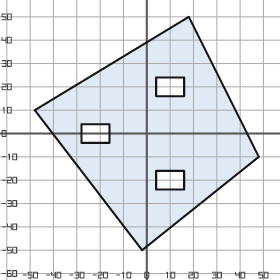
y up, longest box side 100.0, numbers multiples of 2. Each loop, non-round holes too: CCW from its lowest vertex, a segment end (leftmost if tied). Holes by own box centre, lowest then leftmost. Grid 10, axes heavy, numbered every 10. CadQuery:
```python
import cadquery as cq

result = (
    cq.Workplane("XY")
    .moveTo(-2.0, -50.0)
    .lineTo(48.0, -10.0)
    .lineTo(18.0, 50.0)
    .lineTo(-48.0, 10.0)
    .close()
    .moveTo(4.0, -24.0)
    .lineTo(16.0, -24.0)
    .lineTo(16.0, -16.0)
    .lineTo(4.0, -16.0)
    .close()
    .moveTo(-28.0, -4.0)
    .lineTo(-16.0, -4.0)
    .lineTo(-16.0, 4.0)
    .lineTo(-28.0, 4.0)
    .close()
    .moveTo(4.0, 16.0)
    .lineTo(16.0, 16.0)
    .lineTo(16.0, 24.0)
    .lineTo(4.0, 24.0)
    .close()
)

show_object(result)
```